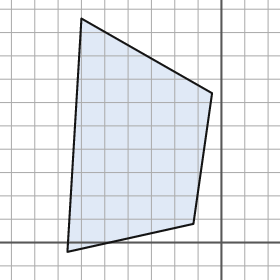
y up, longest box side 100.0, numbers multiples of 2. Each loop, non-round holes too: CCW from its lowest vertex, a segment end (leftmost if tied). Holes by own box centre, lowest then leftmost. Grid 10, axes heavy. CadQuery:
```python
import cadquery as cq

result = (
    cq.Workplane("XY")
    .moveTo(-66.0, -4.0)
    .lineTo(-12.0, 8.0)
    .lineTo(-4.0, 64.0)
    .lineTo(-60.0, 96.0)
    .close()
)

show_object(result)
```